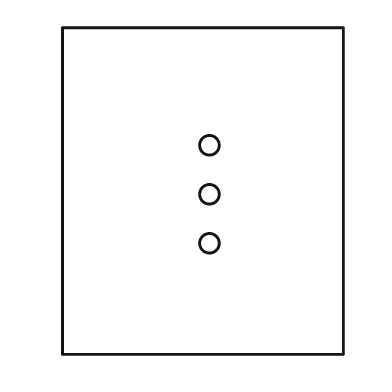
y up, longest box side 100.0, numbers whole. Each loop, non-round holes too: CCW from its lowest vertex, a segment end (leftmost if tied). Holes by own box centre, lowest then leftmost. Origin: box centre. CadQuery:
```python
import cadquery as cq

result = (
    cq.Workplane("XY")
    .moveTo(-43.0, -50.0)
    .lineTo(43.0, -50.0)
    .lineTo(43.0, 50.0)
    .lineTo(-43.0, 50.0)
    .close()
    .moveTo(2.0, -16.0)
    .circle(3.0)
    .moveTo(2.0, -1.0)
    .circle(3.0)
    .moveTo(2.0, 14.0)
    .circle(3.0)
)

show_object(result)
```